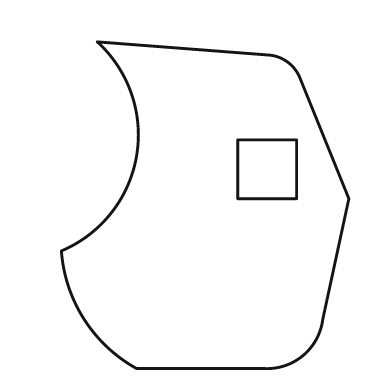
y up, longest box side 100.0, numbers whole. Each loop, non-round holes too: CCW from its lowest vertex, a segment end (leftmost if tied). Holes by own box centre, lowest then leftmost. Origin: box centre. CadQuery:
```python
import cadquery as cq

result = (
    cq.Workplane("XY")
    .moveTo(-21.0, -50.0)
    .lineTo(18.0, -50.0)
    .threePointArc((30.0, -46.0), (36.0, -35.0))
    .lineTo(44.0, 2.0)
    .lineTo(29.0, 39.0)
    .threePointArc((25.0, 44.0), (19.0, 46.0))
    .lineTo(-33.0, 50.0)
    .threePointArc((-21.0, 15.0), (-44.0, -14.0))
    .threePointArc((-37.0, -35.0), (-21.0, -50.0))
    .close()
    .moveTo(10.0, 2.0)
    .lineTo(28.0, 2.0)
    .lineTo(28.0, 20.0)
    .lineTo(10.0, 20.0)
    .close()
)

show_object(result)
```